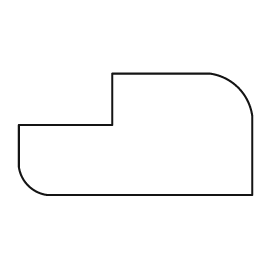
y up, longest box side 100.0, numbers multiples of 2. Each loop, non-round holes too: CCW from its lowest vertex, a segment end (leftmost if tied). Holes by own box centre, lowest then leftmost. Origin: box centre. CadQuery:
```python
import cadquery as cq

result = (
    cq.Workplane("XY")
    .moveTo(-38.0, -26.0)
    .lineTo(50.0, -26.0)
    .lineTo(50.0, 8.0)
    .threePointArc((44.0, 20.0), (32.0, 26.0))
    .lineTo(-10.0, 26.0)
    .lineTo(-10.0, 4.0)
    .lineTo(-50.0, 4.0)
    .lineTo(-50.0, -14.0)
    .threePointArc((-46.0, -22.0), (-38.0, -26.0))
    .close()
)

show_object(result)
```